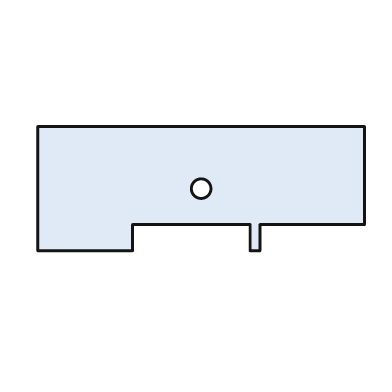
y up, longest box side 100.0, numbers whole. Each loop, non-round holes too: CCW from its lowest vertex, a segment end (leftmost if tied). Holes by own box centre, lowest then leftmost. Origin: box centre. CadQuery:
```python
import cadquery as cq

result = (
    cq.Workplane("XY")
    .moveTo(-50.0, -19.0)
    .lineTo(-21.0, -19.0)
    .lineTo(-21.0, -11.0)
    .lineTo(15.0, -11.0)
    .lineTo(15.0, -19.0)
    .lineTo(18.0, -19.0)
    .lineTo(18.0, -11.0)
    .lineTo(50.0, -11.0)
    .lineTo(50.0, 19.0)
    .lineTo(-50.0, 19.0)
    .close()
    .moveTo(0.0, 0.0)
    .circle(3.0)
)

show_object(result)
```